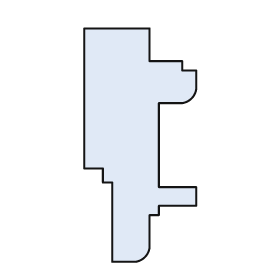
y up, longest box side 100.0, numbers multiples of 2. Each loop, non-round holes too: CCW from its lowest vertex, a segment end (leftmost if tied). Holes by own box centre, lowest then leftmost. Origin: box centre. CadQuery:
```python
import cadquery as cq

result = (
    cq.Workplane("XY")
    .moveTo(-12.0, -50.0)
    .lineTo(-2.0, -50.0)
    .threePointArc((2.0, -48.0), (4.0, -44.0))
    .lineTo(4.0, -30.0)
    .lineTo(8.0, -30.0)
    .lineTo(8.0, -26.0)
    .lineTo(24.0, -26.0)
    .lineTo(24.0, -18.0)
    .lineTo(8.0, -18.0)
    .lineTo(8.0, 18.0)
    .lineTo(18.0, 18.0)
    .threePointArc((22.0, 20.0), (24.0, 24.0))
    .lineTo(24.0, 32.0)
    .lineTo(18.0, 32.0)
    .lineTo(18.0, 36.0)
    .lineTo(4.0, 36.0)
    .lineTo(4.0, 50.0)
    .lineTo(-24.0, 50.0)
    .lineTo(-24.0, -10.0)
    .lineTo(-16.0, -10.0)
    .lineTo(-16.0, -16.0)
    .lineTo(-12.0, -16.0)
    .close()
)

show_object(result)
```